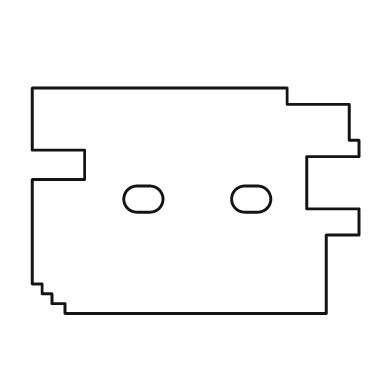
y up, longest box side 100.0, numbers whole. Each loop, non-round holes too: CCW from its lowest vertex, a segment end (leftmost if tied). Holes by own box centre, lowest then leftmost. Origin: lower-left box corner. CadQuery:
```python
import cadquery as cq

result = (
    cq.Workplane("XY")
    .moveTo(10.0, 0.0)
    .lineTo(90.0, 0.0)
    .lineTo(90.0, 24.0)
    .lineTo(100.0, 24.0)
    .lineTo(100.0, 32.0)
    .lineTo(84.0, 32.0)
    .lineTo(84.0, 48.0)
    .lineTo(100.0, 48.0)
    .lineTo(100.0, 53.0)
    .lineTo(97.0, 53.0)
    .lineTo(97.0, 64.0)
    .lineTo(78.0, 64.0)
    .lineTo(78.0, 69.0)
    .lineTo(0.0, 69.0)
    .lineTo(0.0, 50.0)
    .lineTo(16.0, 50.0)
    .lineTo(16.0, 41.0)
    .lineTo(0.0, 41.0)
    .lineTo(0.0, 9.0)
    .lineTo(3.0, 9.0)
    .lineTo(3.0, 6.0)
    .lineTo(6.0, 6.0)
    .lineTo(6.0, 3.0)
    .lineTo(10.0, 3.0)
    .close()
    .moveTo(32.0, 31.0)
    .lineTo(36.0, 31.0)
    .threePointArc((40.0, 35.0), (36.0, 39.0))
    .lineTo(32.0, 39.0)
    .threePointArc((28.0, 35.0), (32.0, 31.0))
    .close()
    .moveTo(65.0, 31.0)
    .lineTo(69.0, 31.0)
    .threePointArc((73.0, 35.0), (69.0, 39.0))
    .lineTo(65.0, 39.0)
    .threePointArc((61.0, 35.0), (65.0, 31.0))
    .close()
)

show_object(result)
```